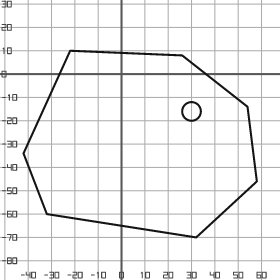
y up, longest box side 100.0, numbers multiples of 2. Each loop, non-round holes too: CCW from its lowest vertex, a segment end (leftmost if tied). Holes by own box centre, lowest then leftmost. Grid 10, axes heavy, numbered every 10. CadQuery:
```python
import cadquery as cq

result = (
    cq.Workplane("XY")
    .moveTo(32.0, -70.0)
    .lineTo(58.0, -46.0)
    .lineTo(54.0, -14.0)
    .lineTo(26.0, 8.0)
    .lineTo(-22.0, 10.0)
    .lineTo(-42.0, -34.0)
    .lineTo(-32.0, -60.0)
    .close()
    .moveTo(30.0, -16.0)
    .circle(4.0)
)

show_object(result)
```